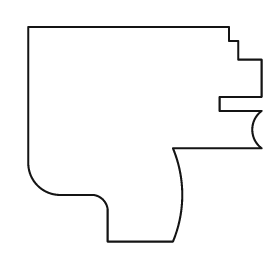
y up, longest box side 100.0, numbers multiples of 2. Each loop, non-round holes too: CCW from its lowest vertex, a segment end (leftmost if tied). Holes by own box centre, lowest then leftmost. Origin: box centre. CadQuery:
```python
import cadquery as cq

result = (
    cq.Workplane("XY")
    .moveTo(-16.0, -46.0)
    .lineTo(12.0, -46.0)
    .threePointArc((16.0, -26.0), (12.0, -6.0))
    .lineTo(50.0, -6.0)
    .threePointArc((46.0, 2.0), (50.0, 10.0))
    .lineTo(32.0, 10.0)
    .lineTo(32.0, 16.0)
    .lineTo(50.0, 16.0)
    .lineTo(50.0, 32.0)
    .lineTo(40.0, 32.0)
    .lineTo(40.0, 40.0)
    .lineTo(36.0, 40.0)
    .lineTo(36.0, 46.0)
    .lineTo(-50.0, 46.0)
    .lineTo(-50.0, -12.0)
    .threePointArc((-46.0, -22.0), (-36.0, -26.0))
    .lineTo(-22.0, -26.0)
    .threePointArc((-18.0, -28.0), (-16.0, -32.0))
    .close()
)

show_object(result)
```